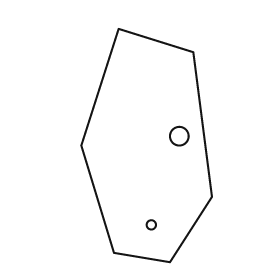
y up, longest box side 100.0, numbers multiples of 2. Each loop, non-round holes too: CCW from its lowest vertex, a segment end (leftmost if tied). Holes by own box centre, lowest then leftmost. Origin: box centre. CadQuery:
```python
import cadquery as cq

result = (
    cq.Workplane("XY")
    .moveTo(10.0, -50.0)
    .lineTo(28.0, -22.0)
    .lineTo(20.0, 40.0)
    .lineTo(-12.0, 50.0)
    .lineTo(-28.0, 0.0)
    .lineTo(-14.0, -46.0)
    .close()
    .moveTo(2.0, -34.0)
    .circle(2.0)
    .moveTo(14.0, 4.0)
    .circle(4.0)
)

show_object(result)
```